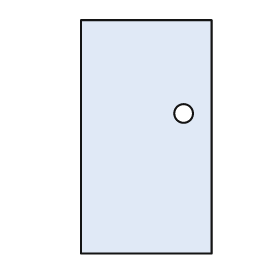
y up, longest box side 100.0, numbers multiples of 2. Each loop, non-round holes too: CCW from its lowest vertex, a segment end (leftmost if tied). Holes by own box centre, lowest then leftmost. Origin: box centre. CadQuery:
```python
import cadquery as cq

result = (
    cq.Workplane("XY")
    .moveTo(-28.0, -50.0)
    .lineTo(28.0, -50.0)
    .lineTo(28.0, 50.0)
    .lineTo(-28.0, 50.0)
    .close()
    .moveTo(16.0, 10.0)
    .circle(4.0)
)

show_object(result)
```